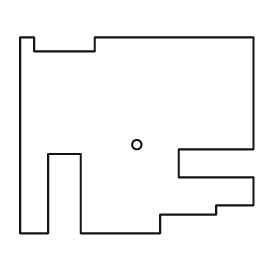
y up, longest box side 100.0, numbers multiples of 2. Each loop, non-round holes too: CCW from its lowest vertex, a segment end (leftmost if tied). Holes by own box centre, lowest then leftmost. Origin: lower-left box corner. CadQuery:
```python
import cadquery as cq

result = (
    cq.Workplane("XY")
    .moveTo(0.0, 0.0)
    .lineTo(12.0, 0.0)
    .lineTo(12.0, 34.0)
    .lineTo(26.0, 34.0)
    .lineTo(26.0, 0.0)
    .lineTo(60.0, 0.0)
    .lineTo(60.0, 8.0)
    .lineTo(84.0, 8.0)
    .lineTo(84.0, 12.0)
    .lineTo(100.0, 12.0)
    .lineTo(100.0, 24.0)
    .lineTo(68.0, 24.0)
    .lineTo(68.0, 36.0)
    .lineTo(100.0, 36.0)
    .lineTo(100.0, 84.0)
    .lineTo(32.0, 84.0)
    .lineTo(32.0, 78.0)
    .lineTo(6.0, 78.0)
    .lineTo(6.0, 84.0)
    .lineTo(0.0, 84.0)
    .close()
    .moveTo(50.0, 38.0)
    .circle(2.0)
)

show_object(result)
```